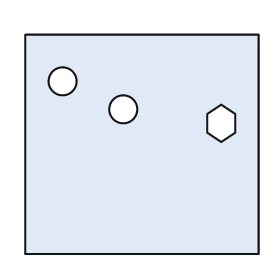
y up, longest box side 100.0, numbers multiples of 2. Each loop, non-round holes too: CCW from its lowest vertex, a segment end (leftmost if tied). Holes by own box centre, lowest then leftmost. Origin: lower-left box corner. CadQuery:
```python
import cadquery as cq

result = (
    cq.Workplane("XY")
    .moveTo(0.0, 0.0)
    .lineTo(100.0, 0.0)
    .lineTo(100.0, 94.0)
    .lineTo(0.0, 94.0)
    .close()
    .moveTo(84.0, 48.0)
    .lineTo(90.0, 52.0)
    .lineTo(90.0, 60.0)
    .lineTo(84.0, 64.0)
    .lineTo(78.0, 60.0)
    .lineTo(78.0, 52.0)
    .close()
    .moveTo(42.0, 62.0)
    .circle(6.0)
    .moveTo(16.0, 74.0)
    .circle(6.0)
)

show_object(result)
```